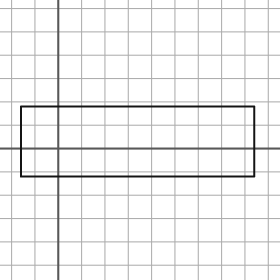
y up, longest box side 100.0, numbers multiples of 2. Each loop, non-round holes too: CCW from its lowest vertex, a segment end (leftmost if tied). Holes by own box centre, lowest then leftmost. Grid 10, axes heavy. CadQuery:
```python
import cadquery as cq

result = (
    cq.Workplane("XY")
    .moveTo(-16.0, -12.0)
    .lineTo(84.0, -12.0)
    .lineTo(84.0, 18.0)
    .lineTo(-16.0, 18.0)
    .close()
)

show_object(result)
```